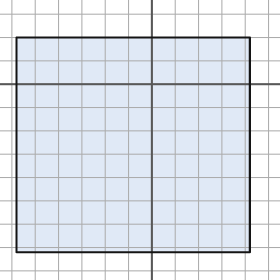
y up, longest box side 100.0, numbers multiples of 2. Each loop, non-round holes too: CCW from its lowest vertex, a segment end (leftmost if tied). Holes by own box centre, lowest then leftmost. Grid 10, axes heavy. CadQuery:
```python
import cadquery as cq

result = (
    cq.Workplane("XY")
    .moveTo(-58.0, -72.0)
    .lineTo(42.0, -72.0)
    .lineTo(42.0, 20.0)
    .lineTo(-58.0, 20.0)
    .close()
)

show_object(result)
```